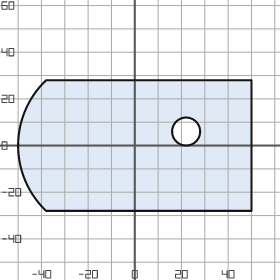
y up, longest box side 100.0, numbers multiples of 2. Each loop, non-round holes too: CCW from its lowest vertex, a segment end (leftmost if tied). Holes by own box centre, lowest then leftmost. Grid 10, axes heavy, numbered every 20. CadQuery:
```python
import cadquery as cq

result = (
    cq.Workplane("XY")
    .moveTo(-38.0, -28.0)
    .lineTo(50.0, -28.0)
    .lineTo(50.0, 28.0)
    .lineTo(-38.0, 28.0)
    .threePointArc((-50.0, 0.0), (-38.0, -28.0))
    .close()
    .moveTo(22.0, 6.0)
    .circle(6.0)
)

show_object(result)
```